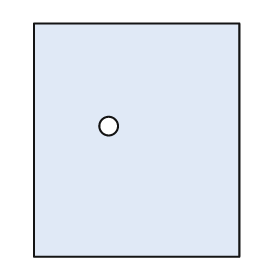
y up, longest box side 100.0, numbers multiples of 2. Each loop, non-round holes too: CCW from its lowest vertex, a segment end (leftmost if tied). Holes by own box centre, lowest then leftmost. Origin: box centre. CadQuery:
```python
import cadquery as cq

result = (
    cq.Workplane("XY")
    .moveTo(-44.0, -50.0)
    .lineTo(44.0, -50.0)
    .lineTo(44.0, 50.0)
    .lineTo(-44.0, 50.0)
    .close()
    .moveTo(-12.0, 6.0)
    .circle(4.0)
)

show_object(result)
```